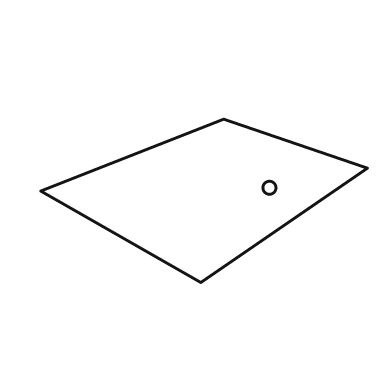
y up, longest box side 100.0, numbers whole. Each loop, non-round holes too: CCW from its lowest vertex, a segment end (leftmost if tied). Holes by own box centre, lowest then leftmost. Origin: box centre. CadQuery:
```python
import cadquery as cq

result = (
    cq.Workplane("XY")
    .moveTo(-1.0, -25.0)
    .lineTo(50.0, 10.0)
    .lineTo(6.0, 25.0)
    .lineTo(-50.0, 3.0)
    .close()
    .moveTo(20.0, 4.0)
    .circle(2.0)
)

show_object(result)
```